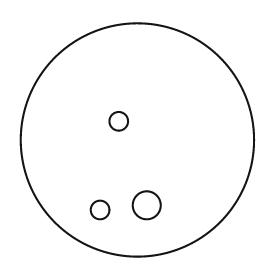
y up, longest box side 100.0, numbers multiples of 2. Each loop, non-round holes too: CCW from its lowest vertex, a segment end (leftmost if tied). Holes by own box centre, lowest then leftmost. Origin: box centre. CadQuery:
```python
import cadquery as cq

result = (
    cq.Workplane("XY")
    .moveTo(0.0, 0.0)
    .circle(50.0)
    .moveTo(-16.0, -30.0)
    .circle(4.0)
    .moveTo(4.0, -28.0)
    .circle(6.0)
    .moveTo(-8.0, 8.0)
    .circle(4.0)
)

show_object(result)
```